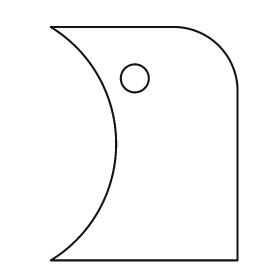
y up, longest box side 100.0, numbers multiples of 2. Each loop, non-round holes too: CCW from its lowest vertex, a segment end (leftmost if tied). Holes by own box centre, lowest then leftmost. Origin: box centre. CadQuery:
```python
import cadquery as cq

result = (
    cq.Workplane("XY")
    .moveTo(-40.0, -50.0)
    .lineTo(40.0, -50.0)
    .lineTo(40.0, 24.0)
    .threePointArc((32.0, 42.0), (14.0, 50.0))
    .lineTo(-40.0, 50.0)
    .threePointArc((-12.0, 0.0), (-40.0, -50.0))
    .close()
    .moveTo(-4.0, 28.0)
    .circle(6.0)
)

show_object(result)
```